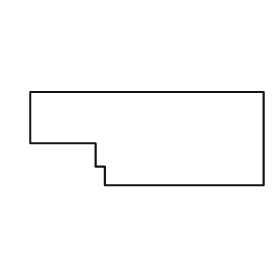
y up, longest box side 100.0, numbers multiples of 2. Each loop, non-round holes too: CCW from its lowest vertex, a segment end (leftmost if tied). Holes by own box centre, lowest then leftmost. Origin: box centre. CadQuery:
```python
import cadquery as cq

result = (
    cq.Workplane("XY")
    .moveTo(-18.0, -20.0)
    .lineTo(50.0, -20.0)
    .lineTo(50.0, 20.0)
    .lineTo(-50.0, 20.0)
    .lineTo(-50.0, -2.0)
    .lineTo(-22.0, -2.0)
    .lineTo(-22.0, -12.0)
    .lineTo(-18.0, -12.0)
    .close()
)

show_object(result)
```